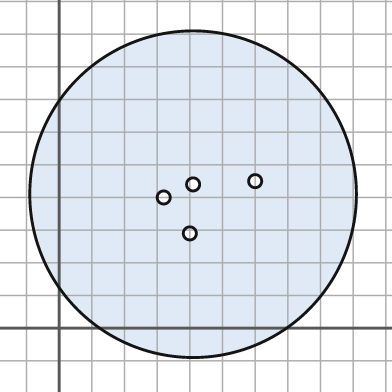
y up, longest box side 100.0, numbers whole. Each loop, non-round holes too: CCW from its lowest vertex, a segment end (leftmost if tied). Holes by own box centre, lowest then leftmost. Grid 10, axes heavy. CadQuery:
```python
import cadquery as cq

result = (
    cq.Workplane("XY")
    .moveTo(41.0, 41.0)
    .circle(50.0)
    .moveTo(40.0, 29.0)
    .circle(2.0)
    .moveTo(32.0, 40.0)
    .circle(2.0)
    .moveTo(41.0, 44.0)
    .circle(2.0)
    .moveTo(60.0, 45.0)
    .circle(2.0)
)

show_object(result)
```